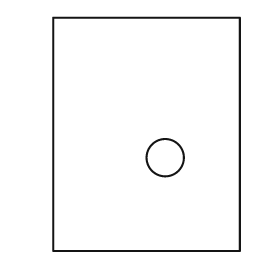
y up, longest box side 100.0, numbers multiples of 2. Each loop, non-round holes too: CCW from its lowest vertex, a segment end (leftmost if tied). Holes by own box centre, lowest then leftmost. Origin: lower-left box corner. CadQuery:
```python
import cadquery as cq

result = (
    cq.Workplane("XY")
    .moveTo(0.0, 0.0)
    .lineTo(80.0, 0.0)
    .lineTo(80.0, 100.0)
    .lineTo(0.0, 100.0)
    .close()
    .moveTo(48.0, 40.0)
    .circle(8.0)
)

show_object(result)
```